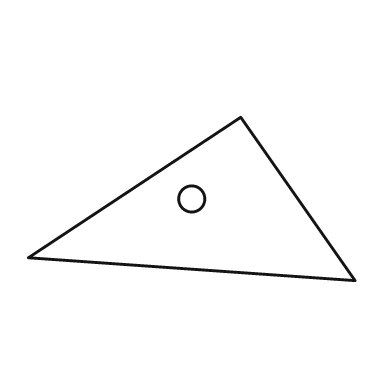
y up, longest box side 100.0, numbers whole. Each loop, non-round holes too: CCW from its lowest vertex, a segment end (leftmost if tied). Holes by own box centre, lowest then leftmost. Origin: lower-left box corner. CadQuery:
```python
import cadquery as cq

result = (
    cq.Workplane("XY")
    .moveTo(100.0, 0.0)
    .lineTo(65.0, 50.0)
    .lineTo(0.0, 7.0)
    .close()
    .moveTo(50.0, 25.0)
    .circle(4.0)
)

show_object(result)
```